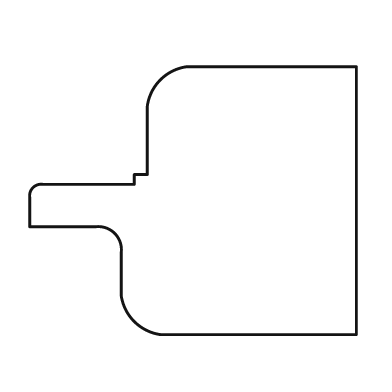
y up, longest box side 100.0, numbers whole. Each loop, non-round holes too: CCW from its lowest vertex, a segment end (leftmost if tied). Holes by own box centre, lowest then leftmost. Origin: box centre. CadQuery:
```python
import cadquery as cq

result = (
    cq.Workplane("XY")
    .moveTo(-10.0, -41.0)
    .lineTo(50.0, -41.0)
    .lineTo(50.0, 41.0)
    .lineTo(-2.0, 41.0)
    .threePointArc((-10.0, 37.0), (-14.0, 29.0))
    .lineTo(-14.0, 8.0)
    .lineTo(-18.0, 8.0)
    .lineTo(-18.0, 5.0)
    .lineTo(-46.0, 5.0)
    .threePointArc((-49.0, 4.0), (-50.0, 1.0))
    .lineTo(-50.0, -8.0)
    .lineTo(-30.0, -8.0)
    .threePointArc((-24.0, -10.0), (-22.0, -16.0))
    .lineTo(-22.0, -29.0)
    .threePointArc((-18.0, -37.0), (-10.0, -41.0))
    .close()
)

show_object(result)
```